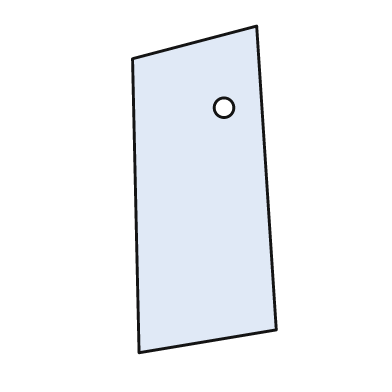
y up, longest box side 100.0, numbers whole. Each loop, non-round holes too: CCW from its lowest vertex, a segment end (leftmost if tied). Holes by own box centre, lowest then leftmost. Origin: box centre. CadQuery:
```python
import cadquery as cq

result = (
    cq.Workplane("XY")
    .moveTo(-20.0, -50.0)
    .lineTo(22.0, -43.0)
    .lineTo(16.0, 50.0)
    .lineTo(-22.0, 40.0)
    .close()
    .moveTo(6.0, 25.0)
    .circle(3.0)
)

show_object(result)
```